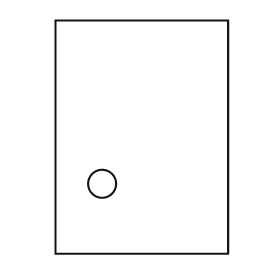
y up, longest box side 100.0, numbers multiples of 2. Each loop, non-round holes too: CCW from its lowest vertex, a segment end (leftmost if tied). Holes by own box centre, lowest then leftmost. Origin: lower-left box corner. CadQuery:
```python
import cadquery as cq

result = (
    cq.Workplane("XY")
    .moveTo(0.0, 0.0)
    .lineTo(74.0, 0.0)
    .lineTo(74.0, 100.0)
    .lineTo(0.0, 100.0)
    .close()
    .moveTo(20.0, 30.0)
    .circle(6.0)
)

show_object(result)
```